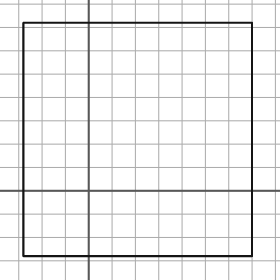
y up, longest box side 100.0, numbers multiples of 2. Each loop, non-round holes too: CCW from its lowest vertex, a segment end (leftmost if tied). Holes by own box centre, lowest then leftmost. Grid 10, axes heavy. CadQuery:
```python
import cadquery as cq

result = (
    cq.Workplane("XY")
    .moveTo(-28.0, -28.0)
    .lineTo(70.0, -28.0)
    .lineTo(70.0, 72.0)
    .lineTo(-28.0, 72.0)
    .close()
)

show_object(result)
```